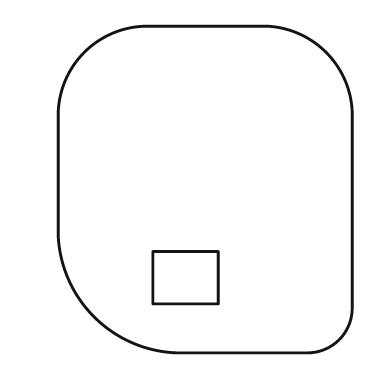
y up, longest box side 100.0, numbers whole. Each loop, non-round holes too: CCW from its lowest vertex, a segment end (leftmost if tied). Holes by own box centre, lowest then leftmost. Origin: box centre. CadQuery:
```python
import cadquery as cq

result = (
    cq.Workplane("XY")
    .moveTo(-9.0, -50.0)
    .lineTo(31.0, -50.0)
    .threePointArc((41.0, -46.0), (45.0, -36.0))
    .lineTo(45.0, 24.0)
    .threePointArc((37.0, 42.0), (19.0, 50.0))
    .lineTo(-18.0, 50.0)
    .threePointArc((-37.0, 42.0), (-45.0, 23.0))
    .lineTo(-45.0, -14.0)
    .threePointArc((-34.0, -39.0), (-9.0, -50.0))
    .close()
    .moveTo(-16.0, -35.0)
    .lineTo(4.0, -35.0)
    .lineTo(4.0, -19.0)
    .lineTo(-16.0, -19.0)
    .close()
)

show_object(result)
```